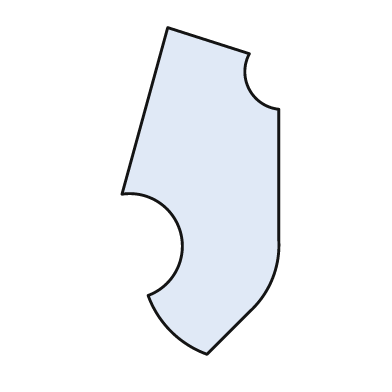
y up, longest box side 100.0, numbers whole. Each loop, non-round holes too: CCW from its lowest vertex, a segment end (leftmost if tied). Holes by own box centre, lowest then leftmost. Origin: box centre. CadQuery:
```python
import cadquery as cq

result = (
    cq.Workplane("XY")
    .moveTo(2.0, -50.0)
    .lineTo(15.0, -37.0)
    .threePointArc((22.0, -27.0), (24.0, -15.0))
    .lineTo(24.0, 25.0)
    .threePointArc((15.0, 31.0), (15.0, 42.0))
    .lineTo(-10.0, 50.0)
    .lineTo(-24.0, -1.0)
    .threePointArc((-6.0, -13.0), (-16.0, -32.0))
    .threePointArc((-9.0, -43.0), (2.0, -50.0))
    .close()
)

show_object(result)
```